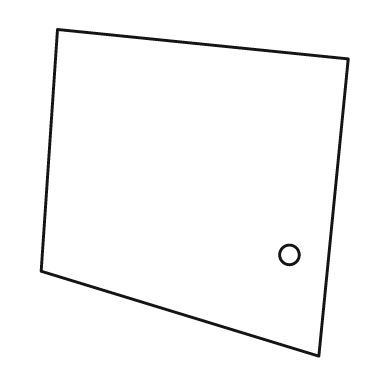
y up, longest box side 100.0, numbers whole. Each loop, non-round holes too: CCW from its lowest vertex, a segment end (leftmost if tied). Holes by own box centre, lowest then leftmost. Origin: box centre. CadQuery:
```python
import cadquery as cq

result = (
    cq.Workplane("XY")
    .moveTo(38.0, -50.0)
    .lineTo(47.0, 41.0)
    .lineTo(-42.0, 50.0)
    .lineTo(-47.0, -24.0)
    .close()
    .moveTo(29.0, -19.0)
    .circle(3.0)
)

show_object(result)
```